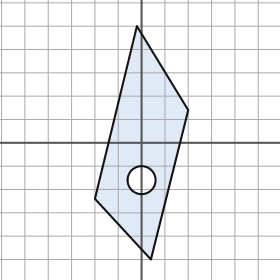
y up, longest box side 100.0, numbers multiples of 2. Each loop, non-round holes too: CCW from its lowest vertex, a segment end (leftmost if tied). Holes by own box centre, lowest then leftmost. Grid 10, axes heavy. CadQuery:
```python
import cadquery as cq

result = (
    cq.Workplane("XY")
    .moveTo(4.0, -50.0)
    .lineTo(20.0, 14.0)
    .lineTo(-2.0, 50.0)
    .lineTo(-20.0, -24.0)
    .close()
    .moveTo(0.0, -16.0)
    .circle(6.0)
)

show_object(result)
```